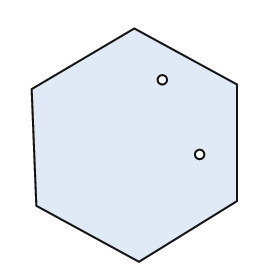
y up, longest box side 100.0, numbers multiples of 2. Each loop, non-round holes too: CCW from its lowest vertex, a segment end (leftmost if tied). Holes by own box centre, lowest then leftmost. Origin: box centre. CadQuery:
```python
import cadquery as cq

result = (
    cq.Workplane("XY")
    .moveTo(2.0, -50.0)
    .lineTo(44.0, -24.0)
    .lineTo(44.0, 26.0)
    .lineTo(0.0, 50.0)
    .lineTo(-44.0, 24.0)
    .lineTo(-42.0, -26.0)
    .close()
    .moveTo(28.0, -4.0)
    .circle(2.0)
    .moveTo(12.0, 28.0)
    .circle(2.0)
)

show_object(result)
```